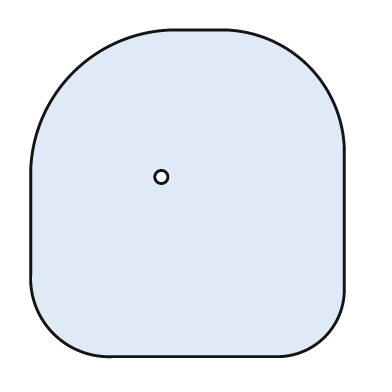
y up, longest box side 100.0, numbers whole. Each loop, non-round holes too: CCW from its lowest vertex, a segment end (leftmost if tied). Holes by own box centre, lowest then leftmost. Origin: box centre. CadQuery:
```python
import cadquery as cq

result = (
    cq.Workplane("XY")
    .moveTo(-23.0, -50.0)
    .lineTo(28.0, -50.0)
    .threePointArc((42.0, -44.0), (48.0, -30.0))
    .lineTo(48.0, 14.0)
    .threePointArc((37.0, 39.0), (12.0, 50.0))
    .lineTo(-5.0, 50.0)
    .threePointArc((-35.0, 37.0), (-48.0, 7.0))
    .lineTo(-48.0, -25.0)
    .threePointArc((-41.0, -43.0), (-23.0, -50.0))
    .close()
    .moveTo(-8.0, 5.0)
    .circle(2.0)
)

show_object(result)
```